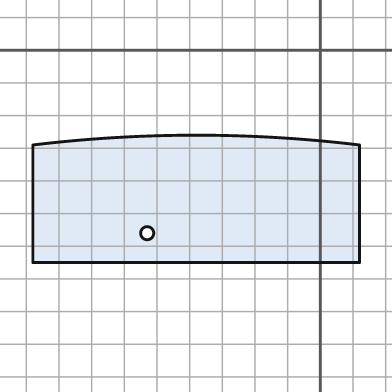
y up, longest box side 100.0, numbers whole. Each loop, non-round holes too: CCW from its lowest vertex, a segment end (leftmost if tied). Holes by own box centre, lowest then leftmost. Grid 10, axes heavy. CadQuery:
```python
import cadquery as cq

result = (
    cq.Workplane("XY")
    .moveTo(-88.0, -65.0)
    .lineTo(12.0, -65.0)
    .lineTo(12.0, -29.0)
    .threePointArc((-38.0, -26.0), (-88.0, -29.0))
    .close()
    .moveTo(-53.0, -56.0)
    .circle(2.0)
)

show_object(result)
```